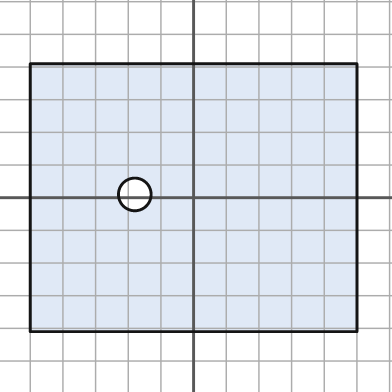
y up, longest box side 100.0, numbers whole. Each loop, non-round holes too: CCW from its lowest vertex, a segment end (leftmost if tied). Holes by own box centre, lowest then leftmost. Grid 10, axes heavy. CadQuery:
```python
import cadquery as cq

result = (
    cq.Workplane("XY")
    .moveTo(-50.0, -41.0)
    .lineTo(50.0, -41.0)
    .lineTo(50.0, 41.0)
    .lineTo(-50.0, 41.0)
    .close()
    .moveTo(-18.0, 1.0)
    .circle(5.0)
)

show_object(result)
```